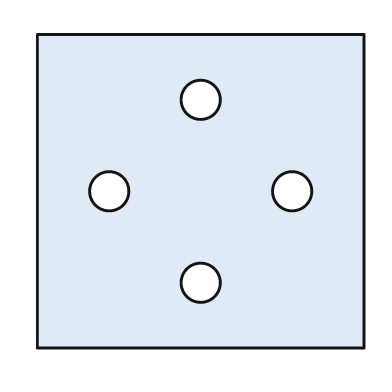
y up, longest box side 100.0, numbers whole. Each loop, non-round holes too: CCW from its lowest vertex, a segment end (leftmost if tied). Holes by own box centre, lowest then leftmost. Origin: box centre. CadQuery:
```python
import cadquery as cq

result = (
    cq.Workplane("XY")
    .moveTo(-50.0, -48.0)
    .lineTo(50.0, -48.0)
    .lineTo(50.0, 48.0)
    .lineTo(-50.0, 48.0)
    .close()
    .moveTo(0.0, -28.0)
    .circle(6.0)
    .moveTo(-28.0, 0.0)
    .circle(6.0)
    .moveTo(28.0, 0.0)
    .circle(6.0)
    .moveTo(0.0, 28.0)
    .circle(6.0)
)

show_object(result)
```